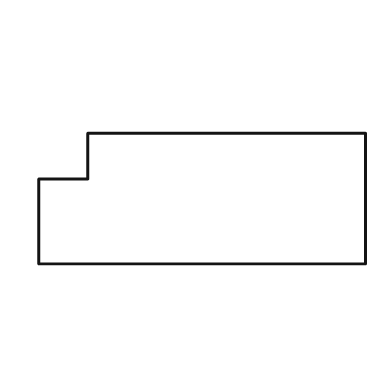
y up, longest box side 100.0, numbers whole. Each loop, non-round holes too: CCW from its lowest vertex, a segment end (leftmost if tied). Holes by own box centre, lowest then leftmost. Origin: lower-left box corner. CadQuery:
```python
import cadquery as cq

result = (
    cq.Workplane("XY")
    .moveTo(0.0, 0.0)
    .lineTo(100.0, 0.0)
    .lineTo(100.0, 40.0)
    .lineTo(15.0, 40.0)
    .lineTo(15.0, 26.0)
    .lineTo(0.0, 26.0)
    .close()
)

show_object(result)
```